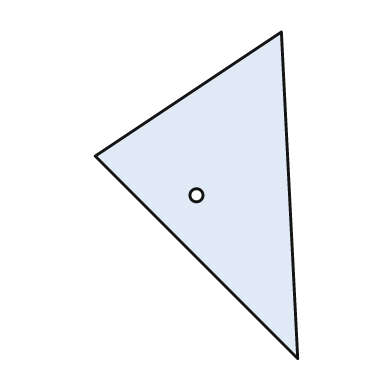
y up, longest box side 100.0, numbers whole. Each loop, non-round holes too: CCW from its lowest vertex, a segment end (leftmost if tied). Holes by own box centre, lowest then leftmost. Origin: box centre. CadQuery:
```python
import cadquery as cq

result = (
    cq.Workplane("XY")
    .moveTo(31.0, -50.0)
    .lineTo(26.0, 50.0)
    .lineTo(-31.0, 12.0)
    .close()
    .moveTo(0.0, 0.0)
    .circle(2.0)
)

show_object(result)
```